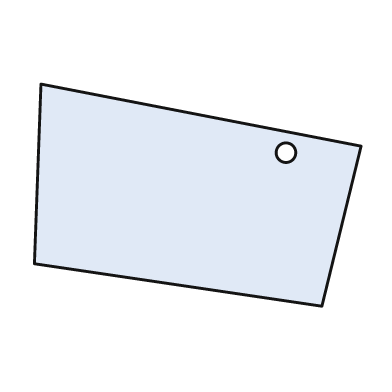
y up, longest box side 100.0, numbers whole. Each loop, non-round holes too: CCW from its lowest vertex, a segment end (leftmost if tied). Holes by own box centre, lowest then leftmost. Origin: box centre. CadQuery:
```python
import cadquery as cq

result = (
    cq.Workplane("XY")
    .moveTo(38.0, -34.0)
    .lineTo(50.0, 15.0)
    .lineTo(-48.0, 34.0)
    .lineTo(-50.0, -21.0)
    .close()
    .moveTo(27.0, 13.0)
    .circle(3.0)
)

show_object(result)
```